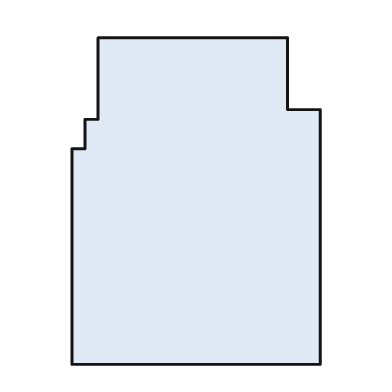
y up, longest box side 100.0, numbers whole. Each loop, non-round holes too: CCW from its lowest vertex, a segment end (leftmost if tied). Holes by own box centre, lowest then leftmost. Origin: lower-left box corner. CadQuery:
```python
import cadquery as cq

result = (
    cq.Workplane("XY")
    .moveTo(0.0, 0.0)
    .lineTo(76.0, 0.0)
    .lineTo(76.0, 78.0)
    .lineTo(66.0, 78.0)
    .lineTo(66.0, 100.0)
    .lineTo(8.0, 100.0)
    .lineTo(8.0, 75.0)
    .lineTo(4.0, 75.0)
    .lineTo(4.0, 66.0)
    .lineTo(0.0, 66.0)
    .close()
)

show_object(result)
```